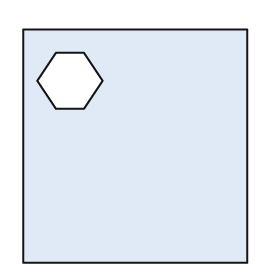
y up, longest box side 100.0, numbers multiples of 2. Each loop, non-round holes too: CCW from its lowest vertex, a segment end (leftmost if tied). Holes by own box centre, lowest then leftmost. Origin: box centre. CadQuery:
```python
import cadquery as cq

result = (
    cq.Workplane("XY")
    .moveTo(-48.0, -50.0)
    .lineTo(48.0, -50.0)
    .lineTo(48.0, 50.0)
    .lineTo(-48.0, 50.0)
    .close()
    .moveTo(-34.0, 16.0)
    .lineTo(-22.0, 16.0)
    .lineTo(-14.0, 28.0)
    .lineTo(-22.0, 40.0)
    .lineTo(-34.0, 40.0)
    .lineTo(-42.0, 28.0)
    .close()
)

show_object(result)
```